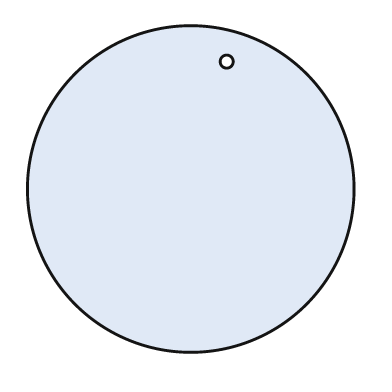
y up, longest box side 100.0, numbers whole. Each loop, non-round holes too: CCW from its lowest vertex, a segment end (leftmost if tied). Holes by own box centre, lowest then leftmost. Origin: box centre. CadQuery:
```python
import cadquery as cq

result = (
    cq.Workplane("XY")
    .moveTo(0.0, 0.0)
    .circle(50.0)
    .moveTo(11.0, 39.0)
    .circle(2.0)
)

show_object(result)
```